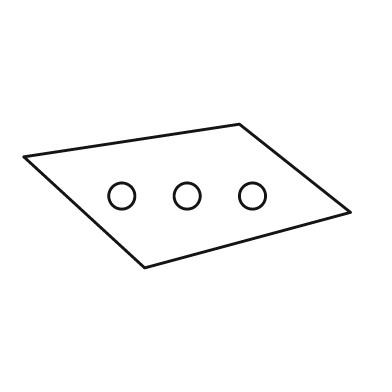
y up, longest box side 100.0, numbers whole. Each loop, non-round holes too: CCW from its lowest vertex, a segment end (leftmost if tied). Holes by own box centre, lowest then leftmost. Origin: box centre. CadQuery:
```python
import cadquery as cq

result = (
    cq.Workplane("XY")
    .moveTo(-13.0, -22.0)
    .lineTo(50.0, -5.0)
    .lineTo(16.0, 22.0)
    .lineTo(-50.0, 12.0)
    .close()
    .moveTo(-20.0, 0.0)
    .circle(4.0)
    .moveTo(0.0, 0.0)
    .circle(4.0)
    .moveTo(20.0, 0.0)
    .circle(4.0)
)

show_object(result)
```